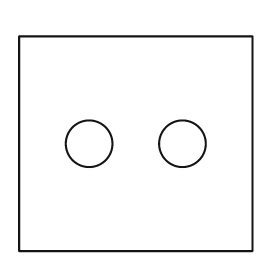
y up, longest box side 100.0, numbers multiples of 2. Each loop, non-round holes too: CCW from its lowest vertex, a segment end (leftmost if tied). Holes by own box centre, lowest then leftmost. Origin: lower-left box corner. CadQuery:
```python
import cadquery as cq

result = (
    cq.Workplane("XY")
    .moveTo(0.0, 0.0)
    .lineTo(100.0, 0.0)
    .lineTo(100.0, 92.0)
    .lineTo(0.0, 92.0)
    .close()
    .moveTo(30.0, 46.0)
    .circle(10.0)
    .moveTo(70.0, 46.0)
    .circle(10.0)
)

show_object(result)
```